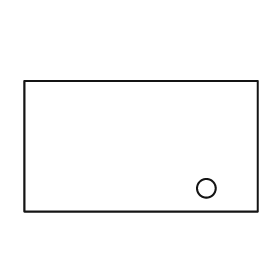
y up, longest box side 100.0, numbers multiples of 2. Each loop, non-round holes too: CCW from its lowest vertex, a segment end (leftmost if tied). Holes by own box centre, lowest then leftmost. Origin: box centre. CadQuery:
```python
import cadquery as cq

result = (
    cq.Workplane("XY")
    .moveTo(-50.0, -28.0)
    .lineTo(50.0, -28.0)
    .lineTo(50.0, 28.0)
    .lineTo(-50.0, 28.0)
    .close()
    .moveTo(28.0, -18.0)
    .circle(4.0)
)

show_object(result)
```